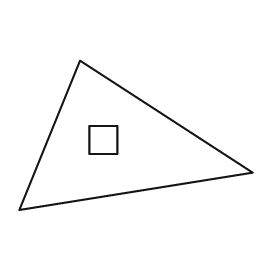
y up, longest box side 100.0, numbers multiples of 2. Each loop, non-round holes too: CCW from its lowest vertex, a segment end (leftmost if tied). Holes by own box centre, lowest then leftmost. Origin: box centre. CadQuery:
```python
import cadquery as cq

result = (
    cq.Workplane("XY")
    .moveTo(-50.0, -32.0)
    .lineTo(50.0, -16.0)
    .lineTo(-24.0, 32.0)
    .close()
    .moveTo(-20.0, -8.0)
    .lineTo(-8.0, -8.0)
    .lineTo(-8.0, 4.0)
    .lineTo(-20.0, 4.0)
    .close()
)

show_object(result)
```